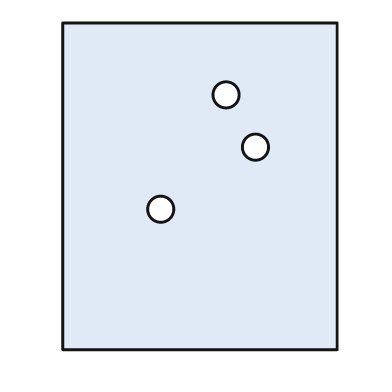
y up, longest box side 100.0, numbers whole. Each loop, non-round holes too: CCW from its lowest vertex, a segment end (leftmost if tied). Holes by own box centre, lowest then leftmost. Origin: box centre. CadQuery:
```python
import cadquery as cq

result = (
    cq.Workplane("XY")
    .moveTo(-42.0, -50.0)
    .lineTo(42.0, -50.0)
    .lineTo(42.0, 50.0)
    .lineTo(-42.0, 50.0)
    .close()
    .moveTo(-12.0, -7.0)
    .circle(4.0)
    .moveTo(17.0, 12.0)
    .circle(4.0)
    .moveTo(8.0, 28.0)
    .circle(4.0)
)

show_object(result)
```